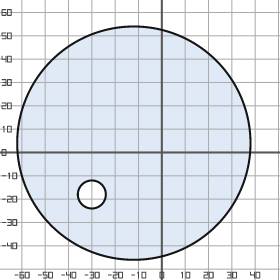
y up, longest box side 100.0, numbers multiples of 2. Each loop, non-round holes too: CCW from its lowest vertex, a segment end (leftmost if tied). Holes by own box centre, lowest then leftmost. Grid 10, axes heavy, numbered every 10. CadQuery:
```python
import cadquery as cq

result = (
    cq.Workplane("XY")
    .moveTo(-12.0, 4.0)
    .circle(50.0)
    .moveTo(-30.0, -18.0)
    .circle(6.0)
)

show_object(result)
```